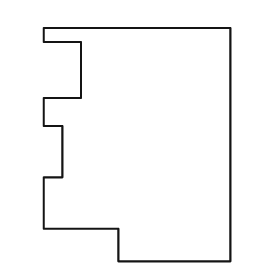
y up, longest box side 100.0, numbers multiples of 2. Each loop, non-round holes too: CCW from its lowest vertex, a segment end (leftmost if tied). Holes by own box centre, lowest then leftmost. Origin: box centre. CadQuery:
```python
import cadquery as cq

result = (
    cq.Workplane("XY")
    .moveTo(-8.0, -50.0)
    .lineTo(40.0, -50.0)
    .lineTo(40.0, 50.0)
    .lineTo(-40.0, 50.0)
    .lineTo(-40.0, 44.0)
    .lineTo(-24.0, 44.0)
    .lineTo(-24.0, 20.0)
    .lineTo(-40.0, 20.0)
    .lineTo(-40.0, 8.0)
    .lineTo(-32.0, 8.0)
    .lineTo(-32.0, -14.0)
    .lineTo(-40.0, -14.0)
    .lineTo(-40.0, -36.0)
    .lineTo(-8.0, -36.0)
    .close()
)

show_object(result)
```